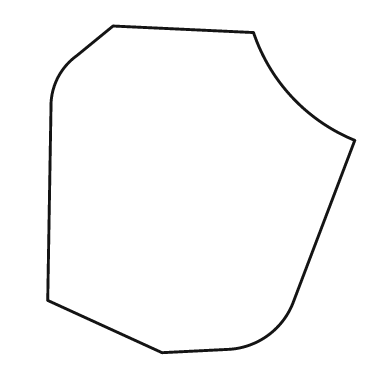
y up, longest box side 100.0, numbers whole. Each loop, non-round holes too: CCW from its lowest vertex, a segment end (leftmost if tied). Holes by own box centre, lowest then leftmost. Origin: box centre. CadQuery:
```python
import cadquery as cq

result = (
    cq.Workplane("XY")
    .moveTo(-12.0, -50.0)
    .lineTo(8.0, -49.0)
    .threePointArc((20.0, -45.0), (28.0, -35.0))
    .lineTo(47.0, 15.0)
    .threePointArc((28.0, 28.0), (16.0, 48.0))
    .lineTo(-27.0, 50.0)
    .lineTo(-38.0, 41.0)
    .threePointArc((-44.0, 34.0), (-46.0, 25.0))
    .lineTo(-47.0, -34.0)
    .close()
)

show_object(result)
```